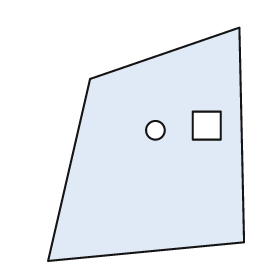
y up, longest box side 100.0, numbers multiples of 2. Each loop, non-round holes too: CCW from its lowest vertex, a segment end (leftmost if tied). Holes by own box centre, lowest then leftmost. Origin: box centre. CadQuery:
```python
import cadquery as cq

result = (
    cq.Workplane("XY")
    .moveTo(-42.0, -50.0)
    .lineTo(42.0, -42.0)
    .lineTo(40.0, 50.0)
    .lineTo(-24.0, 28.0)
    .close()
    .moveTo(4.0, 6.0)
    .circle(4.0)
    .moveTo(20.0, 2.0)
    .lineTo(32.0, 2.0)
    .lineTo(32.0, 14.0)
    .lineTo(20.0, 14.0)
    .close()
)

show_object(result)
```